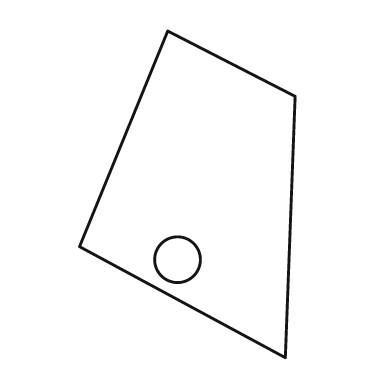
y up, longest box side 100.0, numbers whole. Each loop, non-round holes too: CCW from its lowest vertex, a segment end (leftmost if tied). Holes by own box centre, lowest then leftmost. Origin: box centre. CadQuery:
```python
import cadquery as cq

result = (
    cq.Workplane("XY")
    .moveTo(30.0, -50.0)
    .lineTo(33.0, 30.0)
    .lineTo(-6.0, 50.0)
    .lineTo(-33.0, -16.0)
    .close()
    .moveTo(-3.0, -20.0)
    .circle(7.0)
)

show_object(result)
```